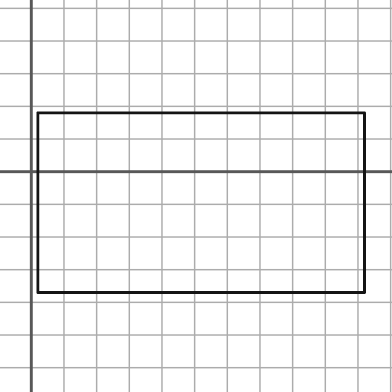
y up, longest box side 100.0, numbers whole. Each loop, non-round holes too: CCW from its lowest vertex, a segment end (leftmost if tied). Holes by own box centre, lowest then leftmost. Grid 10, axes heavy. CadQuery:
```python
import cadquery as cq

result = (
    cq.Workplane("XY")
    .moveTo(2.0, -37.0)
    .lineTo(102.0, -37.0)
    .lineTo(102.0, 18.0)
    .lineTo(2.0, 18.0)
    .close()
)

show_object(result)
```